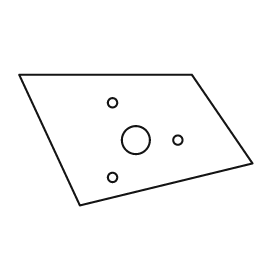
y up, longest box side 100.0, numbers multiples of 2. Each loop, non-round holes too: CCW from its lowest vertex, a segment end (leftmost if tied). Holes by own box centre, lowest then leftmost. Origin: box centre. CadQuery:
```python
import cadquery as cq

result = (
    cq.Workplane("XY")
    .moveTo(-24.0, -28.0)
    .lineTo(50.0, -10.0)
    .lineTo(24.0, 28.0)
    .lineTo(-50.0, 28.0)
    .close()
    .moveTo(-10.0, -16.0)
    .circle(2.0)
    .moveTo(0.0, 0.0)
    .circle(6.0)
    .moveTo(18.0, 0.0)
    .circle(2.0)
    .moveTo(-10.0, 16.0)
    .circle(2.0)
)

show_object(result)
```